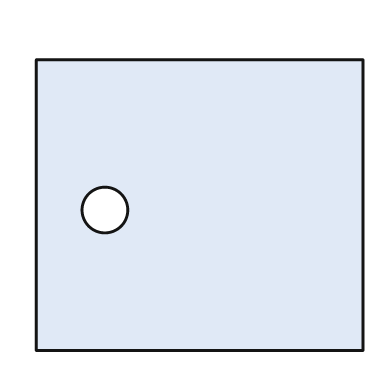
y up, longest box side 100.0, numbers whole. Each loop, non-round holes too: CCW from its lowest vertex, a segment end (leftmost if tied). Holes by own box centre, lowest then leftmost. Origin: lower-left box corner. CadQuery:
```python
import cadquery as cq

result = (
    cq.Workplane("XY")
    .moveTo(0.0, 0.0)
    .lineTo(100.0, 0.0)
    .lineTo(100.0, 89.0)
    .lineTo(0.0, 89.0)
    .close()
    .moveTo(21.0, 43.0)
    .circle(7.0)
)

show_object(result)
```